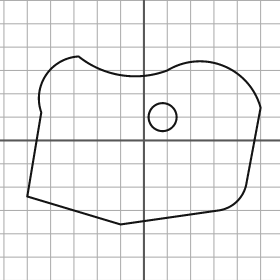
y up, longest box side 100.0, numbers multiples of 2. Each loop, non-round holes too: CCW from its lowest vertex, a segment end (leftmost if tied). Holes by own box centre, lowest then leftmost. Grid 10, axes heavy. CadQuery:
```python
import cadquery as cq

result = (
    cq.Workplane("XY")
    .moveTo(-10.0, -36.0)
    .lineTo(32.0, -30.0)
    .threePointArc((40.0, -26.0), (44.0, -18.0))
    .lineTo(50.0, 14.0)
    .threePointArc((34.0, 32.0), (10.0, 30.0))
    .threePointArc((-10.0, 28.0), (-28.0, 36.0))
    .threePointArc((-42.0, 28.0), (-44.0, 12.0))
    .lineTo(-50.0, -24.0)
    .close()
    .moveTo(8.0, 10.0)
    .circle(6.0)
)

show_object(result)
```